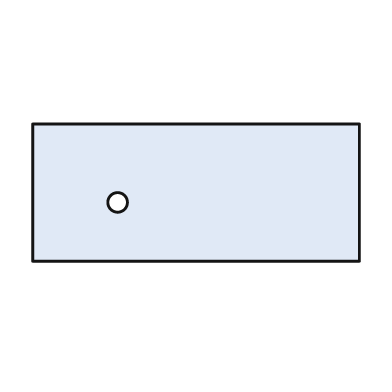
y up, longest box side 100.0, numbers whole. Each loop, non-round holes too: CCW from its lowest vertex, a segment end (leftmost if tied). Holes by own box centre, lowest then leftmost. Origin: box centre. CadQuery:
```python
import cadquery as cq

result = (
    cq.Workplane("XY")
    .moveTo(-50.0, -21.0)
    .lineTo(50.0, -21.0)
    .lineTo(50.0, 21.0)
    .lineTo(-50.0, 21.0)
    .close()
    .moveTo(-24.0, -3.0)
    .circle(3.0)
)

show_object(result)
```